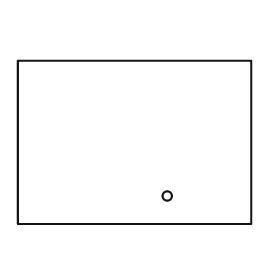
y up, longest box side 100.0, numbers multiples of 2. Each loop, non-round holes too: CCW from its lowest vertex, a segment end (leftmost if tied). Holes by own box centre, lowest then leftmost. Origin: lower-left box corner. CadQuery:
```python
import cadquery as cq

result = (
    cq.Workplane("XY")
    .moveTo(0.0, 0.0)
    .lineTo(100.0, 0.0)
    .lineTo(100.0, 70.0)
    .lineTo(0.0, 70.0)
    .close()
    .moveTo(64.0, 12.0)
    .circle(2.0)
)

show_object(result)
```